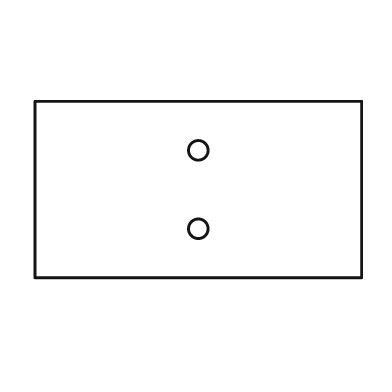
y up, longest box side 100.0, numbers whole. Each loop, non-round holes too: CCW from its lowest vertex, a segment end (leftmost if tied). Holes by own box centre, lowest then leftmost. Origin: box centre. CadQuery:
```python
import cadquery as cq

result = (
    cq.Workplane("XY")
    .moveTo(-50.0, -27.0)
    .lineTo(50.0, -27.0)
    .lineTo(50.0, 27.0)
    .lineTo(-50.0, 27.0)
    .close()
    .moveTo(0.0, -12.0)
    .circle(3.0)
    .moveTo(0.0, 12.0)
    .circle(3.0)
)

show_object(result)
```